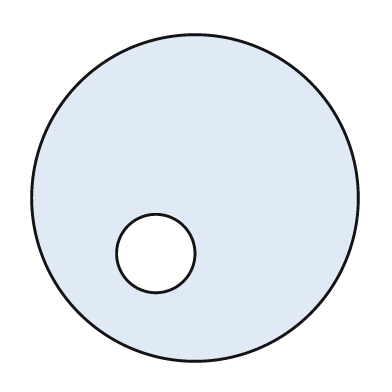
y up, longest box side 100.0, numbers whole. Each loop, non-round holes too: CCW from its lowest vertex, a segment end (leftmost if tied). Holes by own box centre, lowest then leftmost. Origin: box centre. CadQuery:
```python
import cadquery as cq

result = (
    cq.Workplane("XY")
    .moveTo(0.0, 0.0)
    .circle(50.0)
    .moveTo(-12.0, -17.0)
    .circle(12.0)
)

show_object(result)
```